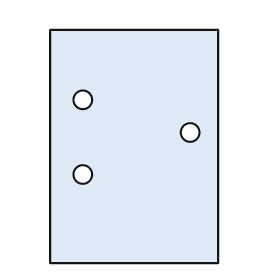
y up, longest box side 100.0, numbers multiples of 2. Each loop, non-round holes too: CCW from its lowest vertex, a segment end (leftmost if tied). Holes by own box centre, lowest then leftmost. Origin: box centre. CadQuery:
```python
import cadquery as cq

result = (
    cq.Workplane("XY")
    .moveTo(-36.0, -50.0)
    .lineTo(36.0, -50.0)
    .lineTo(36.0, 50.0)
    .lineTo(-36.0, 50.0)
    .close()
    .moveTo(-22.0, -12.0)
    .circle(4.0)
    .moveTo(24.0, 6.0)
    .circle(4.0)
    .moveTo(-22.0, 20.0)
    .circle(4.0)
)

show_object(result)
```